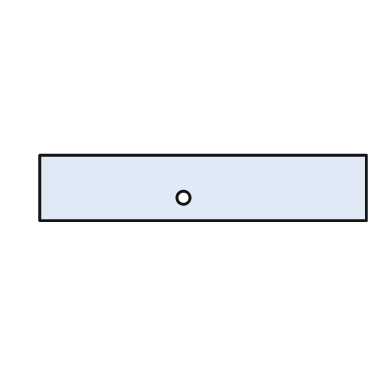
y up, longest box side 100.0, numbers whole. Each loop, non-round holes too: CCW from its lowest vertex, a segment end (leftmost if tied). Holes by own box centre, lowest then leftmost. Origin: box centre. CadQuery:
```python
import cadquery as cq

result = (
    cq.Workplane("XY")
    .moveTo(-50.0, -10.0)
    .lineTo(50.0, -10.0)
    .lineTo(50.0, 10.0)
    .lineTo(-50.0, 10.0)
    .close()
    .moveTo(-6.0, -3.0)
    .circle(2.0)
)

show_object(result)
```